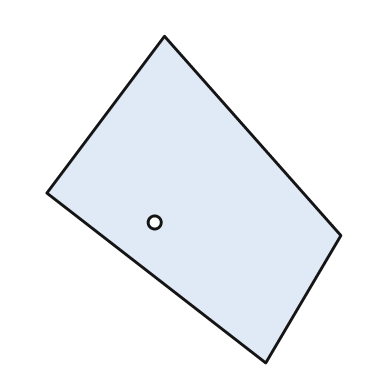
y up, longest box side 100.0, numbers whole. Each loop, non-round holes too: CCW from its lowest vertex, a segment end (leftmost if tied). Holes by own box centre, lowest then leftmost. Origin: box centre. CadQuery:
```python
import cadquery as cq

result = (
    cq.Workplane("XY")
    .moveTo(22.0, -50.0)
    .lineTo(45.0, -11.0)
    .lineTo(-9.0, 50.0)
    .lineTo(-45.0, 2.0)
    .close()
    .moveTo(-12.0, -7.0)
    .circle(2.0)
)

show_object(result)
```